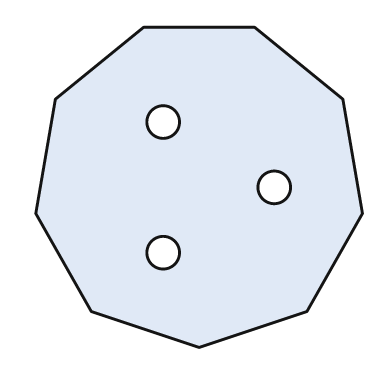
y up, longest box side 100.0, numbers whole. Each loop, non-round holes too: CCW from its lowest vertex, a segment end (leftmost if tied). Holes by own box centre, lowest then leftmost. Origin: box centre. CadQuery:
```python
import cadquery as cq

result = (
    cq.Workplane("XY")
    .moveTo(0.0, -49.0)
    .lineTo(33.0, -38.0)
    .lineTo(50.0, -8.0)
    .lineTo(44.0, 27.0)
    .lineTo(17.0, 49.0)
    .lineTo(-17.0, 49.0)
    .lineTo(-44.0, 27.0)
    .lineTo(-50.0, -8.0)
    .lineTo(-33.0, -38.0)
    .close()
    .moveTo(-11.0, -20.0)
    .circle(5.0)
    .moveTo(23.0, 0.0)
    .circle(5.0)
    .moveTo(-11.0, 20.0)
    .circle(5.0)
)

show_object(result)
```